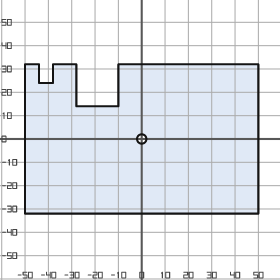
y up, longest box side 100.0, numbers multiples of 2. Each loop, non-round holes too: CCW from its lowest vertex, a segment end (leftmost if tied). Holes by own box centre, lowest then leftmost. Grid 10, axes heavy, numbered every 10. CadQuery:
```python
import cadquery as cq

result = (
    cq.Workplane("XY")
    .moveTo(-50.0, -32.0)
    .lineTo(50.0, -32.0)
    .lineTo(50.0, 32.0)
    .lineTo(-10.0, 32.0)
    .lineTo(-10.0, 14.0)
    .lineTo(-28.0, 14.0)
    .lineTo(-28.0, 32.0)
    .lineTo(-38.0, 32.0)
    .lineTo(-38.0, 24.0)
    .lineTo(-44.0, 24.0)
    .lineTo(-44.0, 32.0)
    .lineTo(-50.0, 32.0)
    .close()
    .moveTo(0.0, 0.0)
    .circle(2.0)
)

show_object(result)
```